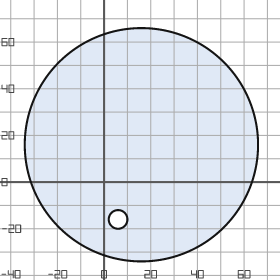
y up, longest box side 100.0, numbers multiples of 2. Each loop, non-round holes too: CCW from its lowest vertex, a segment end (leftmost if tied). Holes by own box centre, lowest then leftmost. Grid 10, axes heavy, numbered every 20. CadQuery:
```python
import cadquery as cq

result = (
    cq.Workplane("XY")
    .moveTo(16.0, 16.0)
    .circle(50.0)
    .moveTo(6.0, -16.0)
    .circle(4.0)
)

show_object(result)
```